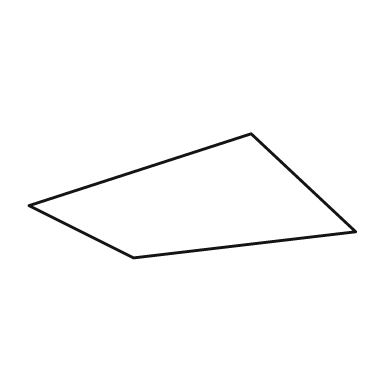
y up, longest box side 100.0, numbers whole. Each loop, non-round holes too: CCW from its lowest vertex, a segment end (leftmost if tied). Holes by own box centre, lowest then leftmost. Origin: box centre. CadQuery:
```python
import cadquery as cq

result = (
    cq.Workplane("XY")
    .moveTo(-18.0, -19.0)
    .lineTo(50.0, -11.0)
    .lineTo(18.0, 19.0)
    .lineTo(-50.0, -3.0)
    .close()
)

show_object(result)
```